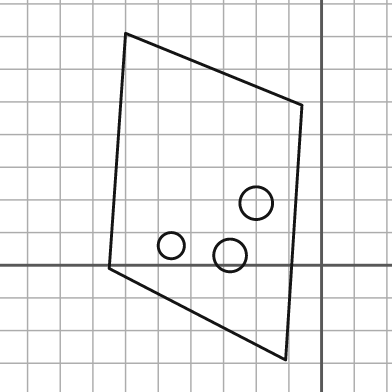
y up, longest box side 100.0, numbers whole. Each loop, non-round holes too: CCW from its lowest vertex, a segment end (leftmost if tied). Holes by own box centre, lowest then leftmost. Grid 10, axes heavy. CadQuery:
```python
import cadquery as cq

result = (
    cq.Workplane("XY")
    .moveTo(-11.0, -29.0)
    .lineTo(-6.0, 49.0)
    .lineTo(-60.0, 71.0)
    .lineTo(-65.0, -1.0)
    .close()
    .moveTo(-28.0, 3.0)
    .circle(5.0)
    .moveTo(-46.0, 6.0)
    .circle(4.0)
    .moveTo(-20.0, 19.0)
    .circle(5.0)
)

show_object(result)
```